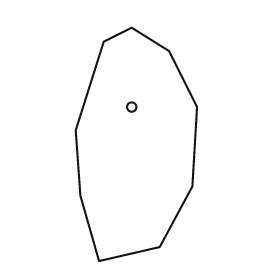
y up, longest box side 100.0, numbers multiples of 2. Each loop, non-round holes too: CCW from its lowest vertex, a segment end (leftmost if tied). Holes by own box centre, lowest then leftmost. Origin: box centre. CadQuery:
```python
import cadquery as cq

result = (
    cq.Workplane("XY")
    .moveTo(-16.0, -50.0)
    .lineTo(10.0, -44.0)
    .lineTo(24.0, -18.0)
    .lineTo(26.0, 16.0)
    .lineTo(14.0, 40.0)
    .lineTo(-2.0, 50.0)
    .lineTo(-14.0, 44.0)
    .lineTo(-26.0, 6.0)
    .lineTo(-24.0, -22.0)
    .close()
    .moveTo(-2.0, 16.0)
    .circle(2.0)
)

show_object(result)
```